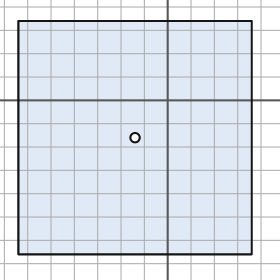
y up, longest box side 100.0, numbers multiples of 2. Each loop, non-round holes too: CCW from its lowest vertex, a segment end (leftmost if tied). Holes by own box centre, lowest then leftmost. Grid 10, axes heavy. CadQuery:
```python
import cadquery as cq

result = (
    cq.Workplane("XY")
    .moveTo(-64.0, -66.0)
    .lineTo(36.0, -66.0)
    .lineTo(36.0, 34.0)
    .lineTo(-64.0, 34.0)
    .close()
    .moveTo(-14.0, -16.0)
    .circle(2.0)
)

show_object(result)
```